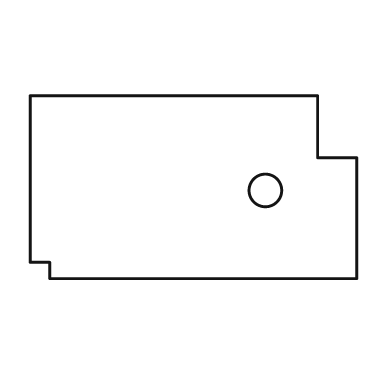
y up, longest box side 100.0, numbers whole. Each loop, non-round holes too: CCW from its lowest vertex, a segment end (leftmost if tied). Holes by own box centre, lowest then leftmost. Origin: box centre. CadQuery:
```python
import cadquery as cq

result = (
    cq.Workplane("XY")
    .moveTo(-44.0, -28.0)
    .lineTo(50.0, -28.0)
    .lineTo(50.0, 9.0)
    .lineTo(38.0, 9.0)
    .lineTo(38.0, 28.0)
    .lineTo(-50.0, 28.0)
    .lineTo(-50.0, -23.0)
    .lineTo(-44.0, -23.0)
    .close()
    .moveTo(22.0, -1.0)
    .circle(5.0)
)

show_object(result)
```